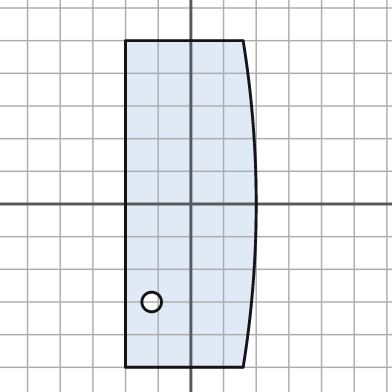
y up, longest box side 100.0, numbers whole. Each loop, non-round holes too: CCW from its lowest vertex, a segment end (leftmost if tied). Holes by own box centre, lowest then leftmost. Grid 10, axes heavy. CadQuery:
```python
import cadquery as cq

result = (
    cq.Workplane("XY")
    .moveTo(-20.0, -50.0)
    .lineTo(16.0, -50.0)
    .threePointArc((20.0, 0.0), (16.0, 50.0))
    .lineTo(-20.0, 50.0)
    .close()
    .moveTo(-12.0, -30.0)
    .circle(3.0)
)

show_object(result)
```